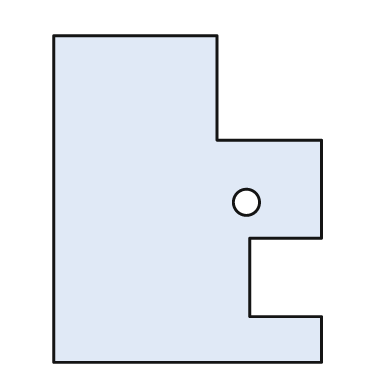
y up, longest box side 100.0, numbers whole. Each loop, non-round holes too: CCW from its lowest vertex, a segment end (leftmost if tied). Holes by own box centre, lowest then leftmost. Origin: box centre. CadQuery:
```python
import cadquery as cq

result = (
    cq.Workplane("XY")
    .moveTo(-41.0, -50.0)
    .lineTo(41.0, -50.0)
    .lineTo(41.0, -36.0)
    .lineTo(19.0, -36.0)
    .lineTo(19.0, -12.0)
    .lineTo(41.0, -12.0)
    .lineTo(41.0, 18.0)
    .lineTo(9.0, 18.0)
    .lineTo(9.0, 50.0)
    .lineTo(-41.0, 50.0)
    .close()
    .moveTo(18.0, -1.0)
    .circle(4.0)
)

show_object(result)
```